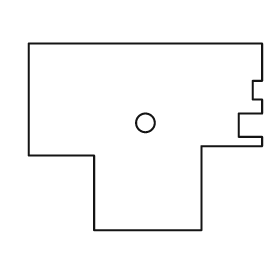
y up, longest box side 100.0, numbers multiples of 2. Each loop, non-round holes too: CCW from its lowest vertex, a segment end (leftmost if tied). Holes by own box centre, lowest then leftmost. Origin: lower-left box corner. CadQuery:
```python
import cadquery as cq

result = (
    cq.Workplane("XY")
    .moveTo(28.0, 0.0)
    .lineTo(74.0, 0.0)
    .lineTo(74.0, 36.0)
    .lineTo(100.0, 36.0)
    .lineTo(100.0, 40.0)
    .lineTo(90.0, 40.0)
    .lineTo(90.0, 50.0)
    .lineTo(100.0, 50.0)
    .lineTo(100.0, 56.0)
    .lineTo(96.0, 56.0)
    .lineTo(96.0, 64.0)
    .lineTo(100.0, 64.0)
    .lineTo(100.0, 80.0)
    .lineTo(0.0, 80.0)
    .lineTo(0.0, 32.0)
    .lineTo(28.0, 32.0)
    .close()
    .moveTo(50.0, 46.0)
    .circle(4.0)
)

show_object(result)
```